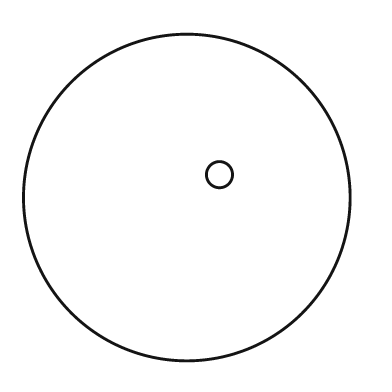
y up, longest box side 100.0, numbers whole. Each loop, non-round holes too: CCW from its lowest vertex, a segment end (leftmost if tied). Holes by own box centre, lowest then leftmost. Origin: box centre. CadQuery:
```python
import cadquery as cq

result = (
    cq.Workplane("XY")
    .moveTo(0.0, 0.0)
    .circle(50.0)
    .moveTo(10.0, 7.0)
    .circle(4.0)
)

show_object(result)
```